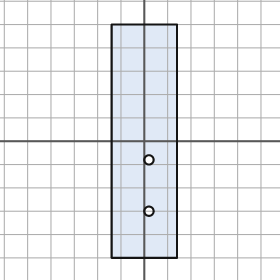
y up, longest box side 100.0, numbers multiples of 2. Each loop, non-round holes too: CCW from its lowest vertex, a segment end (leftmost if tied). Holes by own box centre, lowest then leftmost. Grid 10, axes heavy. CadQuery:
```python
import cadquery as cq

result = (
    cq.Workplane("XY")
    .moveTo(-14.0, -50.0)
    .lineTo(14.0, -50.0)
    .lineTo(14.0, 50.0)
    .lineTo(-14.0, 50.0)
    .close()
    .moveTo(2.0, -30.0)
    .circle(2.0)
    .moveTo(2.0, -8.0)
    .circle(2.0)
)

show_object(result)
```